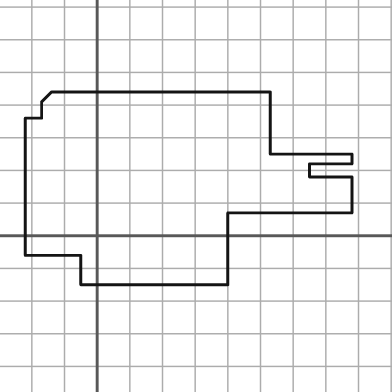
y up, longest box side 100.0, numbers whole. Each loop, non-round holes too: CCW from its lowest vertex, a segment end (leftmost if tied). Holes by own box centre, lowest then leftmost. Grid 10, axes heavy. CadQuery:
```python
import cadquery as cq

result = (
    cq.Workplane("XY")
    .moveTo(-5.0, -15.0)
    .lineTo(40.0, -15.0)
    .lineTo(40.0, 7.0)
    .lineTo(78.0, 7.0)
    .lineTo(78.0, 18.0)
    .lineTo(65.0, 18.0)
    .lineTo(65.0, 22.0)
    .lineTo(78.0, 22.0)
    .lineTo(78.0, 25.0)
    .lineTo(53.0, 25.0)
    .lineTo(53.0, 44.0)
    .lineTo(-14.0, 44.0)
    .lineTo(-17.0, 41.0)
    .lineTo(-17.0, 36.0)
    .lineTo(-22.0, 36.0)
    .lineTo(-22.0, -6.0)
    .lineTo(-5.0, -6.0)
    .close()
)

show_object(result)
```